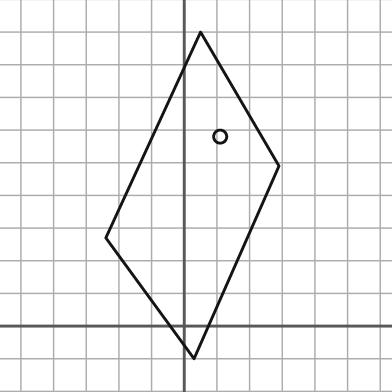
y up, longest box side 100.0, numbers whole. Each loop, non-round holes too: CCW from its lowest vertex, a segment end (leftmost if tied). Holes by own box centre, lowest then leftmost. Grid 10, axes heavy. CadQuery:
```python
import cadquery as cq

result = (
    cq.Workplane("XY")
    .moveTo(3.0, -10.0)
    .lineTo(29.0, 49.0)
    .lineTo(5.0, 90.0)
    .lineTo(-24.0, 27.0)
    .close()
    .moveTo(11.0, 58.0)
    .circle(2.0)
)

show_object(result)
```